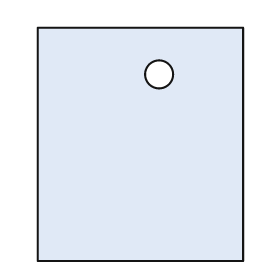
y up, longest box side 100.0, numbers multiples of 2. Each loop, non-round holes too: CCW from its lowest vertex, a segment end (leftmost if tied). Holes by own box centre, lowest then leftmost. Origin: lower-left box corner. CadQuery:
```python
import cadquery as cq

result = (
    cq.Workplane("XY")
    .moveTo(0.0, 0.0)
    .lineTo(88.0, 0.0)
    .lineTo(88.0, 100.0)
    .lineTo(0.0, 100.0)
    .close()
    .moveTo(52.0, 80.0)
    .circle(6.0)
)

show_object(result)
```